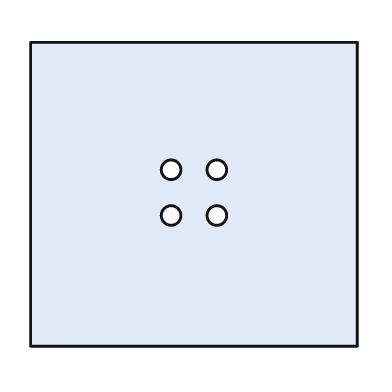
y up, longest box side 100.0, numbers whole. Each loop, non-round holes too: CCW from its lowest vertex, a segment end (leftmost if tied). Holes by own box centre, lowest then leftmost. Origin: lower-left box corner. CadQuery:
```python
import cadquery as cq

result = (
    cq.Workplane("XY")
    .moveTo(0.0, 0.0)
    .lineTo(100.0, 0.0)
    .lineTo(100.0, 93.0)
    .lineTo(0.0, 93.0)
    .close()
    .moveTo(43.0, 40.0)
    .circle(3.0)
    .moveTo(57.0, 40.0)
    .circle(3.0)
    .moveTo(43.0, 54.0)
    .circle(3.0)
    .moveTo(57.0, 54.0)
    .circle(3.0)
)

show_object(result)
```